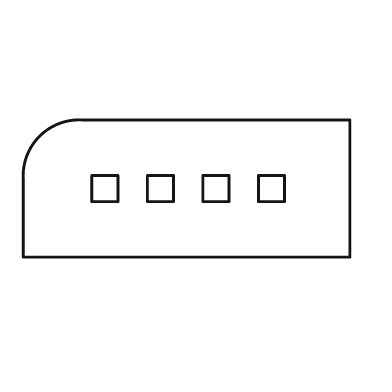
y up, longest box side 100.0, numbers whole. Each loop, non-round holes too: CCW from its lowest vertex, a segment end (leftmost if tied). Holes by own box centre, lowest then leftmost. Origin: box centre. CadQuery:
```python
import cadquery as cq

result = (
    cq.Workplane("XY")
    .moveTo(-50.0, -21.0)
    .lineTo(50.0, -21.0)
    .lineTo(50.0, 21.0)
    .lineTo(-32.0, 21.0)
    .threePointArc((-45.0, 16.0), (-50.0, 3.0))
    .close()
    .moveTo(-29.0, -4.0)
    .lineTo(-21.0, -4.0)
    .lineTo(-21.0, 4.0)
    .lineTo(-29.0, 4.0)
    .close()
    .moveTo(-12.0, -4.0)
    .lineTo(-4.0, -4.0)
    .lineTo(-4.0, 4.0)
    .lineTo(-12.0, 4.0)
    .close()
    .moveTo(5.0, -4.0)
    .lineTo(13.0, -4.0)
    .lineTo(13.0, 4.0)
    .lineTo(5.0, 4.0)
    .close()
    .moveTo(22.0, -4.0)
    .lineTo(30.0, -4.0)
    .lineTo(30.0, 4.0)
    .lineTo(22.0, 4.0)
    .close()
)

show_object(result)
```